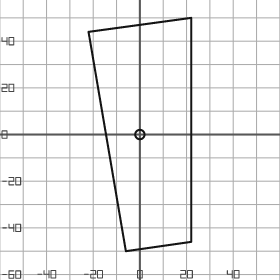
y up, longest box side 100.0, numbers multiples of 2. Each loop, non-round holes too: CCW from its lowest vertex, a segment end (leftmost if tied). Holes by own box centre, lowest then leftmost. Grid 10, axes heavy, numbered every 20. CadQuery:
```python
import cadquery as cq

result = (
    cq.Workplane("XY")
    .moveTo(-6.0, -50.0)
    .lineTo(22.0, -46.0)
    .lineTo(22.0, 50.0)
    .lineTo(-22.0, 44.0)
    .close()
    .moveTo(0.0, 0.0)
    .circle(2.0)
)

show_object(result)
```